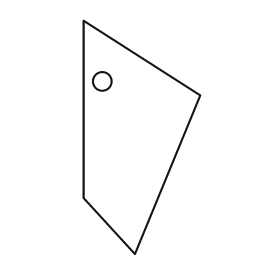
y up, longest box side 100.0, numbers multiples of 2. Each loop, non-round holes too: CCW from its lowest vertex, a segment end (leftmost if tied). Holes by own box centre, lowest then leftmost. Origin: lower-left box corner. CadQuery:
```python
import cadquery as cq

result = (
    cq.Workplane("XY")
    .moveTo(22.0, 0.0)
    .lineTo(50.0, 68.0)
    .lineTo(0.0, 100.0)
    .lineTo(0.0, 24.0)
    .close()
    .moveTo(8.0, 74.0)
    .circle(4.0)
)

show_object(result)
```